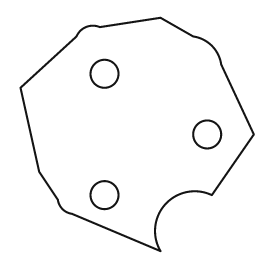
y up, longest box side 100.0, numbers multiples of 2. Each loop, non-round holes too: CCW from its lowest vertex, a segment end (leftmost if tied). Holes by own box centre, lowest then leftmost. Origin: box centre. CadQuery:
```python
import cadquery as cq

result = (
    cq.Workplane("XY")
    .moveTo(10.0, -50.0)
    .threePointArc((12.0, -30.0), (32.0, -26.0))
    .lineTo(50.0, 0.0)
    .lineTo(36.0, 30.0)
    .threePointArc((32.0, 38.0), (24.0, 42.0))
    .lineTo(10.0, 50.0)
    .lineTo(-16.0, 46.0)
    .threePointArc((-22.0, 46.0), (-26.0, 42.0))
    .lineTo(-50.0, 20.0)
    .lineTo(-42.0, -16.0)
    .lineTo(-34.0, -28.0)
    .threePointArc((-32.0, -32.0), (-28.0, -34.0))
    .close()
    .moveTo(-14.0, -26.0)
    .circle(6.0)
    .moveTo(30.0, 0.0)
    .circle(6.0)
    .moveTo(-14.0, 26.0)
    .circle(6.0)
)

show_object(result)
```